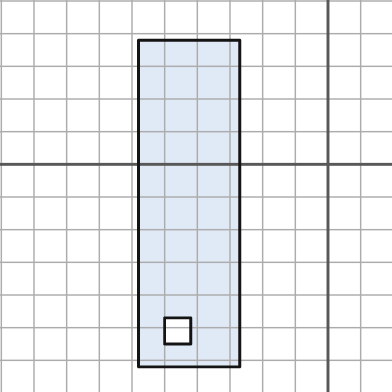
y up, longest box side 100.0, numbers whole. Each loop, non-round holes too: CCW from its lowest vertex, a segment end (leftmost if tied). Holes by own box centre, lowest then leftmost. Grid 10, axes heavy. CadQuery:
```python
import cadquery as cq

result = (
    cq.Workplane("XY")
    .moveTo(-58.0, -62.0)
    .lineTo(-27.0, -62.0)
    .lineTo(-27.0, 38.0)
    .lineTo(-58.0, 38.0)
    .close()
    .moveTo(-50.0, -55.0)
    .lineTo(-42.0, -55.0)
    .lineTo(-42.0, -47.0)
    .lineTo(-50.0, -47.0)
    .close()
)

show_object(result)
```